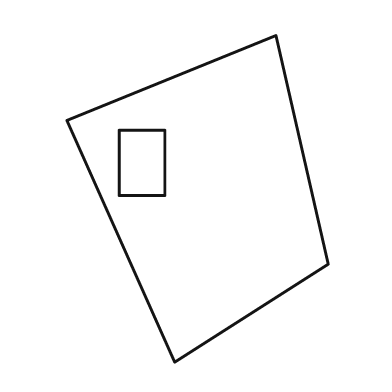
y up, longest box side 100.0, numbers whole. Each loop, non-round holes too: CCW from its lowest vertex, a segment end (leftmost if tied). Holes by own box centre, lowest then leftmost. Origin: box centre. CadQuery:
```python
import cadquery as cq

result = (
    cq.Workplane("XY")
    .moveTo(-7.0, -50.0)
    .lineTo(40.0, -20.0)
    .lineTo(24.0, 50.0)
    .lineTo(-40.0, 24.0)
    .close()
    .moveTo(-24.0, 1.0)
    .lineTo(-10.0, 1.0)
    .lineTo(-10.0, 21.0)
    .lineTo(-24.0, 21.0)
    .close()
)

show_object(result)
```